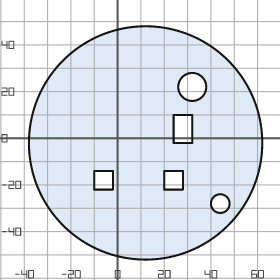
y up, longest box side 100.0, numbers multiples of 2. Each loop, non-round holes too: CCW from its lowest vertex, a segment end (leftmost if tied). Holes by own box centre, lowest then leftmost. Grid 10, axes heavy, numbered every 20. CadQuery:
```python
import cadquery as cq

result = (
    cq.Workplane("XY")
    .moveTo(12.0, -2.0)
    .circle(50.0)
    .moveTo(44.0, -28.0)
    .circle(4.0)
    .moveTo(-10.0, -22.0)
    .lineTo(-2.0, -22.0)
    .lineTo(-2.0, -14.0)
    .lineTo(-10.0, -14.0)
    .close()
    .moveTo(20.0, -22.0)
    .lineTo(28.0, -22.0)
    .lineTo(28.0, -14.0)
    .lineTo(20.0, -14.0)
    .close()
    .moveTo(24.0, -2.0)
    .lineTo(32.0, -2.0)
    .lineTo(32.0, 10.0)
    .lineTo(24.0, 10.0)
    .close()
    .moveTo(32.0, 22.0)
    .circle(6.0)
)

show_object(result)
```